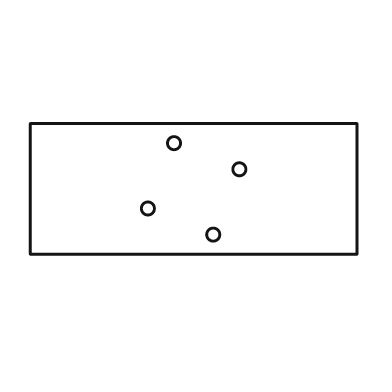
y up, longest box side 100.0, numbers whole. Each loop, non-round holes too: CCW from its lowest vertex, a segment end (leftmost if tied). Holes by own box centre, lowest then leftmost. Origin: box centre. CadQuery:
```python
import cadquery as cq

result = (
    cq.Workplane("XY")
    .moveTo(-50.0, -20.0)
    .lineTo(50.0, -20.0)
    .lineTo(50.0, 20.0)
    .lineTo(-50.0, 20.0)
    .close()
    .moveTo(6.0, -14.0)
    .circle(2.0)
    .moveTo(-14.0, -6.0)
    .circle(2.0)
    .moveTo(14.0, 6.0)
    .circle(2.0)
    .moveTo(-6.0, 14.0)
    .circle(2.0)
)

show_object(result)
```